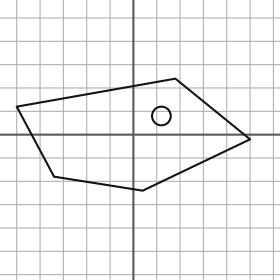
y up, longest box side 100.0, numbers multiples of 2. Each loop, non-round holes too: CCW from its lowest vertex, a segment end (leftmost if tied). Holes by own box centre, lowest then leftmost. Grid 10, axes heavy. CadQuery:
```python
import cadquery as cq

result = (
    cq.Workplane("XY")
    .moveTo(4.0, -24.0)
    .lineTo(50.0, -2.0)
    .lineTo(18.0, 24.0)
    .lineTo(-50.0, 12.0)
    .lineTo(-34.0, -18.0)
    .close()
    .moveTo(12.0, 8.0)
    .circle(4.0)
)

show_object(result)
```